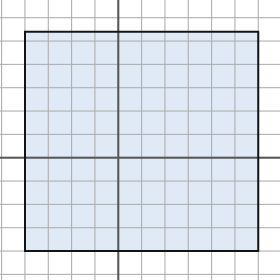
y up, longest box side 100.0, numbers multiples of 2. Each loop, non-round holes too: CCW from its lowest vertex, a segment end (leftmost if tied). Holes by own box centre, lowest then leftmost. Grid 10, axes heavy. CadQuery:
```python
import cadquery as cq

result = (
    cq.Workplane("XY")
    .moveTo(-40.0, -40.0)
    .lineTo(60.0, -40.0)
    .lineTo(60.0, 54.0)
    .lineTo(-40.0, 54.0)
    .close()
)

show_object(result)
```